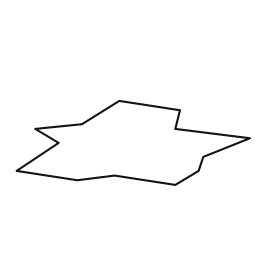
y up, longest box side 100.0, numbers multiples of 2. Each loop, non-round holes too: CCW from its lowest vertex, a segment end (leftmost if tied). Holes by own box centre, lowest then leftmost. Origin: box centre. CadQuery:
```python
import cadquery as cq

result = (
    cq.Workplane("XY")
    .moveTo(18.0, -18.0)
    .lineTo(28.0, -12.0)
    .lineTo(30.0, -6.0)
    .lineTo(50.0, 2.0)
    .lineTo(18.0, 6.0)
    .lineTo(20.0, 14.0)
    .lineTo(-6.0, 18.0)
    .lineTo(-22.0, 8.0)
    .lineTo(-42.0, 6.0)
    .lineTo(-32.0, 0.0)
    .lineTo(-50.0, -12.0)
    .lineTo(-24.0, -16.0)
    .lineTo(-8.0, -14.0)
    .close()
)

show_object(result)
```